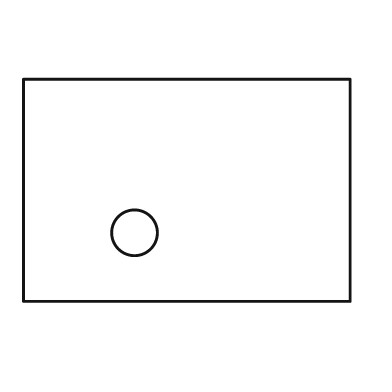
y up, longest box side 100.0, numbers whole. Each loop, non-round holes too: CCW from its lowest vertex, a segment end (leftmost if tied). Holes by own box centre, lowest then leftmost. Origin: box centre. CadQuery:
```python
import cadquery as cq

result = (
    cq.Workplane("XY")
    .moveTo(-50.0, -34.0)
    .lineTo(50.0, -34.0)
    .lineTo(50.0, 34.0)
    .lineTo(-50.0, 34.0)
    .close()
    .moveTo(-16.0, -13.0)
    .circle(7.0)
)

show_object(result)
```